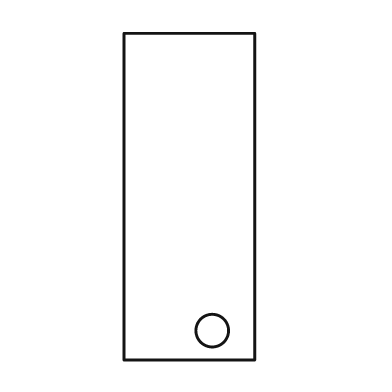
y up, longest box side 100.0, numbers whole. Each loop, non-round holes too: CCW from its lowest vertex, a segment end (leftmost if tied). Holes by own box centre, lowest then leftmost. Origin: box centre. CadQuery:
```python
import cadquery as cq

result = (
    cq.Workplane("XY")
    .moveTo(-20.0, -50.0)
    .lineTo(20.0, -50.0)
    .lineTo(20.0, 50.0)
    .lineTo(-20.0, 50.0)
    .close()
    .moveTo(7.0, -41.0)
    .circle(5.0)
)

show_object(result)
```